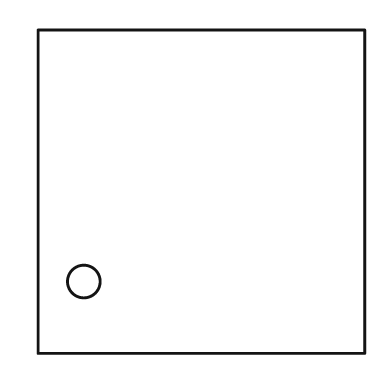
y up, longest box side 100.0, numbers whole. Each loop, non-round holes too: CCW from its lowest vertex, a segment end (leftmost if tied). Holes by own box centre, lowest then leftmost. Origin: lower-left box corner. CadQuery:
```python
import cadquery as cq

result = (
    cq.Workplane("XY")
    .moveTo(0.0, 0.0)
    .lineTo(100.0, 0.0)
    .lineTo(100.0, 99.0)
    .lineTo(0.0, 99.0)
    .close()
    .moveTo(14.0, 22.0)
    .circle(5.0)
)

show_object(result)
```